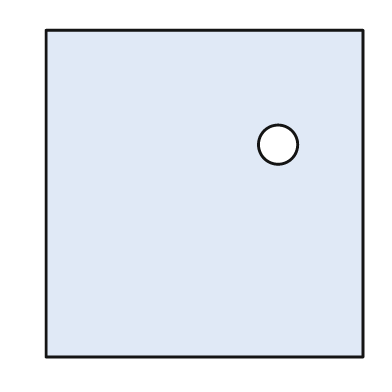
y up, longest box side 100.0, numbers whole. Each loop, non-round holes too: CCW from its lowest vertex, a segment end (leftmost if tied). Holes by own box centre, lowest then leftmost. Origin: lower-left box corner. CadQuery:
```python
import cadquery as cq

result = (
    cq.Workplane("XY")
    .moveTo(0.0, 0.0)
    .lineTo(97.0, 0.0)
    .lineTo(97.0, 100.0)
    .lineTo(0.0, 100.0)
    .close()
    .moveTo(71.0, 65.0)
    .circle(6.0)
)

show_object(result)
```